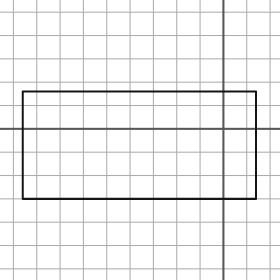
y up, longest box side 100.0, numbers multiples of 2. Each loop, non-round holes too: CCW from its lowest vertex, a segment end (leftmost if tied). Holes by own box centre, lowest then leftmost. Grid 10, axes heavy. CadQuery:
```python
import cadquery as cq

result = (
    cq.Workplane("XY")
    .moveTo(-86.0, -30.0)
    .lineTo(14.0, -30.0)
    .lineTo(14.0, 16.0)
    .lineTo(-86.0, 16.0)
    .close()
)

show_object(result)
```